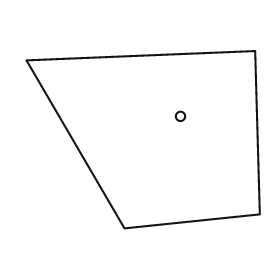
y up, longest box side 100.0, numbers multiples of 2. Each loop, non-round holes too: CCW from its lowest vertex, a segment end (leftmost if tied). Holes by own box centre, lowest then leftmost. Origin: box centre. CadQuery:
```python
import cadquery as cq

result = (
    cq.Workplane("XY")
    .moveTo(-8.0, -38.0)
    .lineTo(50.0, -32.0)
    .lineTo(48.0, 38.0)
    .lineTo(-50.0, 34.0)
    .close()
    .moveTo(16.0, 10.0)
    .circle(2.0)
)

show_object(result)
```